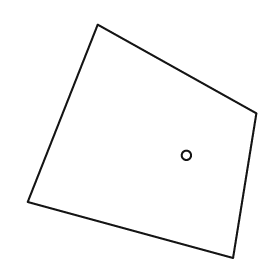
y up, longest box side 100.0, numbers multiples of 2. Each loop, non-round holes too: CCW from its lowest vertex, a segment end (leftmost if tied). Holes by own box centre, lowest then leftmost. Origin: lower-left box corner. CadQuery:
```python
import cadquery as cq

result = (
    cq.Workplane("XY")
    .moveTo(88.0, 0.0)
    .lineTo(98.0, 62.0)
    .lineTo(30.0, 100.0)
    .lineTo(0.0, 24.0)
    .close()
    .moveTo(68.0, 44.0)
    .circle(2.0)
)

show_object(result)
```